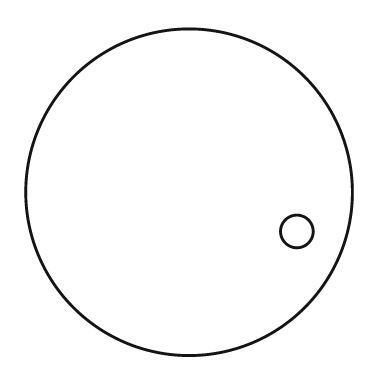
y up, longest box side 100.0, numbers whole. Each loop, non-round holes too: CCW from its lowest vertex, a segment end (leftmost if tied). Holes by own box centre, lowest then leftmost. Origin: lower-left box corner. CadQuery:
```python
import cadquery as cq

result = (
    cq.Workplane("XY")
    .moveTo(50.0, 50.0)
    .circle(50.0)
    .moveTo(83.0, 38.0)
    .circle(5.0)
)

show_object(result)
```